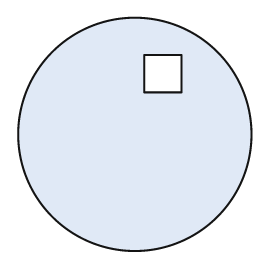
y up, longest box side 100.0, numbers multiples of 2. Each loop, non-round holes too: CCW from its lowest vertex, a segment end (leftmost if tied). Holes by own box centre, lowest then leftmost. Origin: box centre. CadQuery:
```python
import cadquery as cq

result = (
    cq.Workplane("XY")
    .moveTo(0.0, 0.0)
    .circle(50.0)
    .moveTo(4.0, 18.0)
    .lineTo(20.0, 18.0)
    .lineTo(20.0, 34.0)
    .lineTo(4.0, 34.0)
    .close()
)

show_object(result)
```